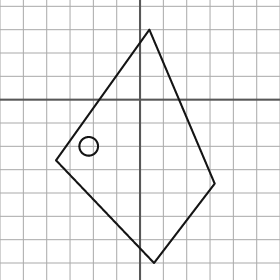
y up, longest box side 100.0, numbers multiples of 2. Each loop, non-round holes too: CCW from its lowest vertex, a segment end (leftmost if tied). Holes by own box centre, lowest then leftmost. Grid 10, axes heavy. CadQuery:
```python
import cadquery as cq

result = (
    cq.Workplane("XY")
    .moveTo(6.0, -70.0)
    .lineTo(32.0, -36.0)
    .lineTo(4.0, 30.0)
    .lineTo(-36.0, -26.0)
    .close()
    .moveTo(-22.0, -20.0)
    .circle(4.0)
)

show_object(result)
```